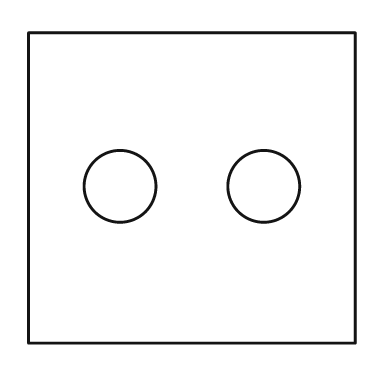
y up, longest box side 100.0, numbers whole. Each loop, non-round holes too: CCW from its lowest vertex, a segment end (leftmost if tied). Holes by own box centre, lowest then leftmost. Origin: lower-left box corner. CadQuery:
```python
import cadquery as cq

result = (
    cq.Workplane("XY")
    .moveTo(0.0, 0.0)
    .lineTo(100.0, 0.0)
    .lineTo(100.0, 95.0)
    .lineTo(0.0, 95.0)
    .close()
    .moveTo(28.0, 48.0)
    .circle(11.0)
    .moveTo(72.0, 48.0)
    .circle(11.0)
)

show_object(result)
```